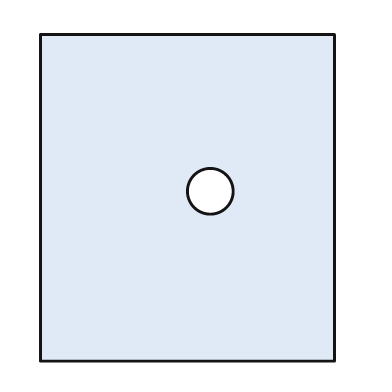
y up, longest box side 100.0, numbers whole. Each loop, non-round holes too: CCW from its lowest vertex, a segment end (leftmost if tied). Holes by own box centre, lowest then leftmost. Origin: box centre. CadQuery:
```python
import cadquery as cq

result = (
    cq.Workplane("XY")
    .moveTo(-45.0, -50.0)
    .lineTo(45.0, -50.0)
    .lineTo(45.0, 50.0)
    .lineTo(-45.0, 50.0)
    .close()
    .moveTo(7.0, 2.0)
    .circle(7.0)
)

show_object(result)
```